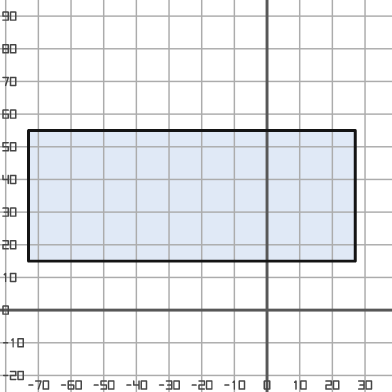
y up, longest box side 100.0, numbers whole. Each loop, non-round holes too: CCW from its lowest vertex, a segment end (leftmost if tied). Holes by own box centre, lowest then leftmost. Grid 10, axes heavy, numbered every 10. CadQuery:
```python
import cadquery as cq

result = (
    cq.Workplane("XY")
    .moveTo(-73.0, 15.0)
    .lineTo(27.0, 15.0)
    .lineTo(27.0, 55.0)
    .lineTo(-73.0, 55.0)
    .close()
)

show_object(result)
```